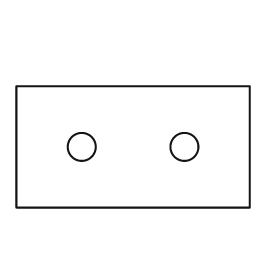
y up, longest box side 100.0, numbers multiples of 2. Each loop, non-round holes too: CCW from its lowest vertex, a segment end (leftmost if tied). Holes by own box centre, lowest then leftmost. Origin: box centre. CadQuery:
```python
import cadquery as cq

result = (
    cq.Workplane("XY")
    .moveTo(-50.0, -26.0)
    .lineTo(50.0, -26.0)
    .lineTo(50.0, 26.0)
    .lineTo(-50.0, 26.0)
    .close()
    .moveTo(-22.0, 0.0)
    .circle(6.0)
    .moveTo(22.0, 0.0)
    .circle(6.0)
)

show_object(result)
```